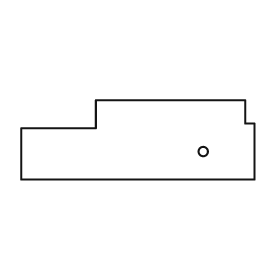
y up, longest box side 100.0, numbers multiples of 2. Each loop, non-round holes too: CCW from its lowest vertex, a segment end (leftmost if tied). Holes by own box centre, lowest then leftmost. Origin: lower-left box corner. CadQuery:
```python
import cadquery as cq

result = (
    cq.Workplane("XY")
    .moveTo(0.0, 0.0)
    .lineTo(100.0, 0.0)
    .lineTo(100.0, 24.0)
    .lineTo(96.0, 24.0)
    .lineTo(96.0, 34.0)
    .lineTo(32.0, 34.0)
    .lineTo(32.0, 22.0)
    .lineTo(0.0, 22.0)
    .close()
    .moveTo(78.0, 12.0)
    .circle(2.0)
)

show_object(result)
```